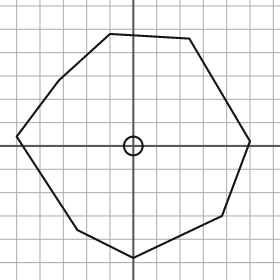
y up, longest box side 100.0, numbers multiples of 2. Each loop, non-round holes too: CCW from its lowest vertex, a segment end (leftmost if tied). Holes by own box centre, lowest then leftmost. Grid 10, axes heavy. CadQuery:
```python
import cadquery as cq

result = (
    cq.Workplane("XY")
    .moveTo(0.0, -48.0)
    .lineTo(38.0, -30.0)
    .lineTo(50.0, 2.0)
    .lineTo(24.0, 46.0)
    .lineTo(-10.0, 48.0)
    .lineTo(-32.0, 28.0)
    .lineTo(-50.0, 4.0)
    .lineTo(-24.0, -36.0)
    .close()
    .moveTo(0.0, 0.0)
    .circle(4.0)
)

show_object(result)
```